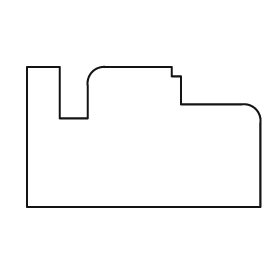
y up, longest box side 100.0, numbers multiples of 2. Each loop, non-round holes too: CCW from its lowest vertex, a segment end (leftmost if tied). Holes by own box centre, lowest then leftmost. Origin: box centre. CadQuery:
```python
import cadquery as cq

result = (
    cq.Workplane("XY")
    .moveTo(-50.0, -30.0)
    .lineTo(50.0, -30.0)
    .lineTo(50.0, 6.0)
    .threePointArc((48.0, 12.0), (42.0, 14.0))
    .lineTo(16.0, 14.0)
    .lineTo(16.0, 26.0)
    .lineTo(12.0, 26.0)
    .lineTo(12.0, 30.0)
    .lineTo(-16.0, 30.0)
    .threePointArc((-22.0, 28.0), (-24.0, 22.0))
    .lineTo(-24.0, 8.0)
    .lineTo(-36.0, 8.0)
    .lineTo(-36.0, 30.0)
    .lineTo(-50.0, 30.0)
    .close()
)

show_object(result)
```